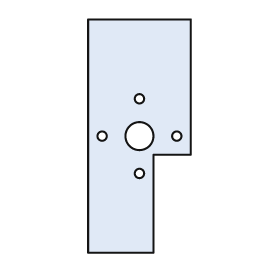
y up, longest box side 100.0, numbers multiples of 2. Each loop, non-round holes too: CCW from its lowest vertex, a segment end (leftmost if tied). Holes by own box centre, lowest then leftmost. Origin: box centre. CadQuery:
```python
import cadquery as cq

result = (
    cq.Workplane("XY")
    .moveTo(-22.0, -50.0)
    .lineTo(6.0, -50.0)
    .lineTo(6.0, -8.0)
    .lineTo(22.0, -8.0)
    .lineTo(22.0, 50.0)
    .lineTo(-22.0, 50.0)
    .close()
    .moveTo(0.0, -16.0)
    .circle(2.0)
    .moveTo(-16.0, 0.0)
    .circle(2.0)
    .moveTo(0.0, 0.0)
    .circle(6.0)
    .moveTo(16.0, 0.0)
    .circle(2.0)
    .moveTo(0.0, 16.0)
    .circle(2.0)
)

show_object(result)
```